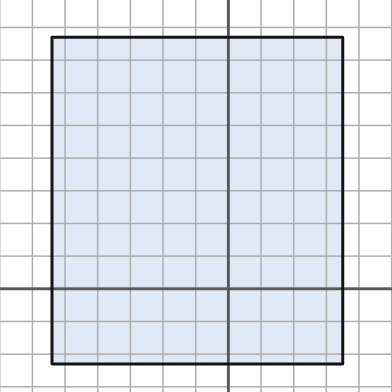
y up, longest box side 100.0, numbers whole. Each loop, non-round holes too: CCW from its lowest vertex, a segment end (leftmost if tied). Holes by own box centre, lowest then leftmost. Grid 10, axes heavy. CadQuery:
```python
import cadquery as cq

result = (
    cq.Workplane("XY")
    .moveTo(-54.0, -23.0)
    .lineTo(35.0, -23.0)
    .lineTo(35.0, 77.0)
    .lineTo(-54.0, 77.0)
    .close()
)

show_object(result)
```